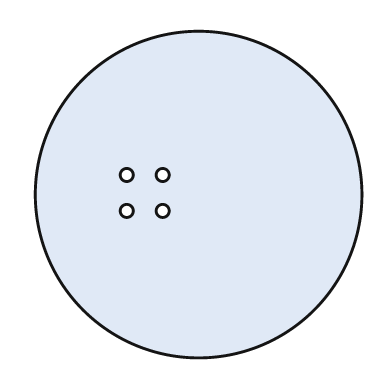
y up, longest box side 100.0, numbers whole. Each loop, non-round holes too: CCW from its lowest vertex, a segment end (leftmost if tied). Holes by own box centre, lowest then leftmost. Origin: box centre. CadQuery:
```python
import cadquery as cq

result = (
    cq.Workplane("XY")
    .moveTo(0.0, 0.0)
    .circle(50.0)
    .moveTo(-22.0, -5.0)
    .circle(2.0)
    .moveTo(-11.0, -5.0)
    .circle(2.0)
    .moveTo(-22.0, 6.0)
    .circle(2.0)
    .moveTo(-11.0, 6.0)
    .circle(2.0)
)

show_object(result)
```